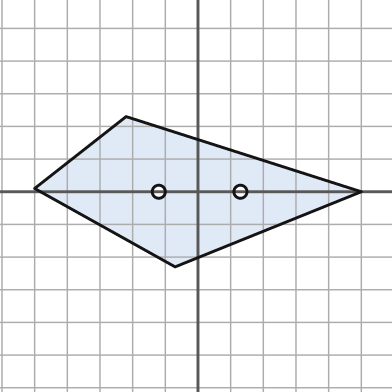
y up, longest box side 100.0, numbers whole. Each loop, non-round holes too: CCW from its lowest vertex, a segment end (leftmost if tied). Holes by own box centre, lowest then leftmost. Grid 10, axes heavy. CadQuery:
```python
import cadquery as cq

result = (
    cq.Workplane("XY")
    .moveTo(-7.0, -23.0)
    .lineTo(50.0, 0.0)
    .lineTo(-22.0, 23.0)
    .lineTo(-50.0, 1.0)
    .close()
    .moveTo(-12.0, 0.0)
    .circle(2.0)
    .moveTo(13.0, 0.0)
    .circle(2.0)
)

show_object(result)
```